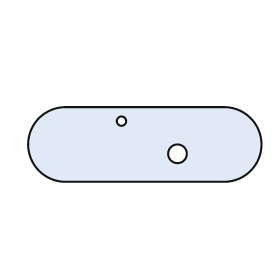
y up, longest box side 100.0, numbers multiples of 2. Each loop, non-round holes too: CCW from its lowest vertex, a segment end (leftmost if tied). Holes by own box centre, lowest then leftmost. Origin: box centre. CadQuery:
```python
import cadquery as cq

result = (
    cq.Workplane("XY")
    .moveTo(-34.0, -16.0)
    .lineTo(34.0, -16.0)
    .threePointArc((50.0, 0.0), (34.0, 16.0))
    .lineTo(-34.0, 16.0)
    .threePointArc((-50.0, 0.0), (-34.0, -16.0))
    .close()
    .moveTo(14.0, -4.0)
    .circle(4.0)
    .moveTo(-10.0, 10.0)
    .circle(2.0)
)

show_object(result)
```